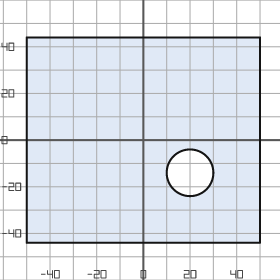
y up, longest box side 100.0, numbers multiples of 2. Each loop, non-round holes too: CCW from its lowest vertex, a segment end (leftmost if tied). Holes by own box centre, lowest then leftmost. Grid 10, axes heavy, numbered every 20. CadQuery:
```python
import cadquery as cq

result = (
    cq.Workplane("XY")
    .moveTo(-50.0, -44.0)
    .lineTo(50.0, -44.0)
    .lineTo(50.0, 44.0)
    .lineTo(-50.0, 44.0)
    .close()
    .moveTo(20.0, -14.0)
    .circle(10.0)
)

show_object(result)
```